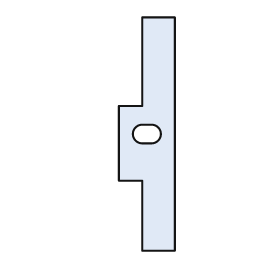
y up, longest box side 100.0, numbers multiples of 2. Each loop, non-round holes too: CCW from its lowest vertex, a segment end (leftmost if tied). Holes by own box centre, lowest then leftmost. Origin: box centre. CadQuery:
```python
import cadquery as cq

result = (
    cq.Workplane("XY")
    .moveTo(-2.0, -50.0)
    .lineTo(12.0, -50.0)
    .lineTo(12.0, 50.0)
    .lineTo(-2.0, 50.0)
    .lineTo(-2.0, 12.0)
    .lineTo(-12.0, 12.0)
    .lineTo(-12.0, -20.0)
    .lineTo(-2.0, -20.0)
    .close()
    .moveTo(-2.0, -4.0)
    .lineTo(2.0, -4.0)
    .threePointArc((6.0, 0.0), (2.0, 4.0))
    .lineTo(-2.0, 4.0)
    .threePointArc((-6.0, 0.0), (-2.0, -4.0))
    .close()
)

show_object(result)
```